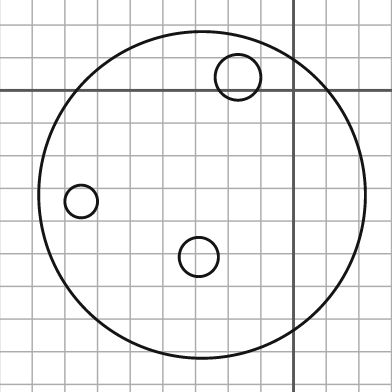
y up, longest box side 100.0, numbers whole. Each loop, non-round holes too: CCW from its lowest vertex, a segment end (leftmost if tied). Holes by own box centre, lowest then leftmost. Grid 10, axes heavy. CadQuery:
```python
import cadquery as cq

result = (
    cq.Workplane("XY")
    .moveTo(-28.0, -32.0)
    .circle(50.0)
    .moveTo(-29.0, -51.0)
    .circle(6.0)
    .moveTo(-65.0, -34.0)
    .circle(5.0)
    .moveTo(-17.0, 4.0)
    .circle(7.0)
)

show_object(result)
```